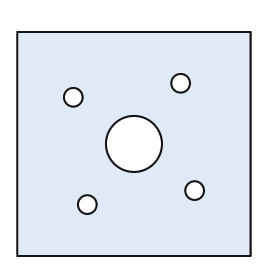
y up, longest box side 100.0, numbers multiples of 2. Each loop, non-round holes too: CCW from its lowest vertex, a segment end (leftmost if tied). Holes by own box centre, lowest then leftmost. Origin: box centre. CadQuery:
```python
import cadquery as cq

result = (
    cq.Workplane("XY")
    .moveTo(-50.0, -48.0)
    .lineTo(50.0, -48.0)
    .lineTo(50.0, 48.0)
    .lineTo(-50.0, 48.0)
    .close()
    .moveTo(-20.0, -26.0)
    .circle(4.0)
    .moveTo(26.0, -20.0)
    .circle(4.0)
    .moveTo(0.0, 0.0)
    .circle(12.0)
    .moveTo(-26.0, 20.0)
    .circle(4.0)
    .moveTo(20.0, 26.0)
    .circle(4.0)
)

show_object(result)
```